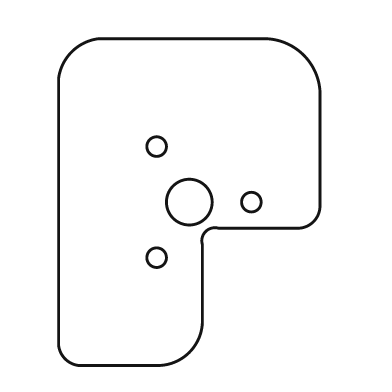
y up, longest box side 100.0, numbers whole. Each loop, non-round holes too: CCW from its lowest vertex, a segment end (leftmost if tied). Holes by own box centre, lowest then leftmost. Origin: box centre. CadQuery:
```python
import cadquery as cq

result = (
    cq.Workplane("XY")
    .moveTo(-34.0, -50.0)
    .lineTo(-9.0, -50.0)
    .threePointArc((0.0, -46.0), (4.0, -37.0))
    .lineTo(4.0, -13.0)
    .threePointArc((5.0, -9.0), (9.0, -8.0))
    .lineTo(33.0, -8.0)
    .threePointArc((38.0, -6.0), (40.0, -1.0))
    .lineTo(40.0, 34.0)
    .threePointArc((35.0, 45.0), (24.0, 50.0))
    .lineTo(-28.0, 50.0)
    .threePointArc((-36.0, 46.0), (-40.0, 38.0))
    .lineTo(-40.0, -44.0)
    .threePointArc((-38.0, -48.0), (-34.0, -50.0))
    .close()
    .moveTo(-10.0, -17.0)
    .circle(3.0)
    .moveTo(0.0, 0.0)
    .circle(7.0)
    .moveTo(19.0, 0.0)
    .circle(3.0)
    .moveTo(-10.0, 17.0)
    .circle(3.0)
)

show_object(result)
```